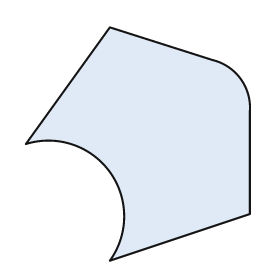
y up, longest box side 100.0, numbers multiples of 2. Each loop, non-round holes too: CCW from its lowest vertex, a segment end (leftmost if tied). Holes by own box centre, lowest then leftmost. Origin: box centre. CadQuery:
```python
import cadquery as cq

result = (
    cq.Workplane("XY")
    .moveTo(-12.0, -50.0)
    .lineTo(48.0, -30.0)
    .lineTo(48.0, 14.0)
    .threePointArc((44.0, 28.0), (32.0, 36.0))
    .lineTo(-12.0, 50.0)
    .lineTo(-48.0, 0.0)
    .threePointArc((-12.0, -12.0), (-12.0, -50.0))
    .close()
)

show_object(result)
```